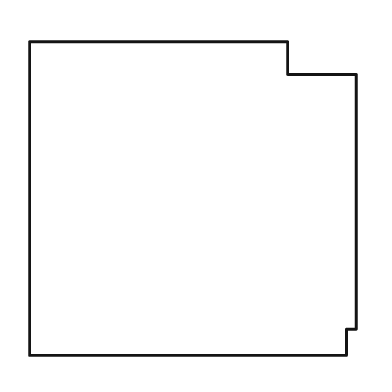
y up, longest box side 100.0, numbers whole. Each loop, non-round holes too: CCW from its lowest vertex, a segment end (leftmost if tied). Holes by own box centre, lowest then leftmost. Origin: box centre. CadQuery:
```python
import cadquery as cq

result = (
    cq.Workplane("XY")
    .moveTo(-50.0, -48.0)
    .lineTo(47.0, -48.0)
    .lineTo(47.0, -40.0)
    .lineTo(50.0, -40.0)
    .lineTo(50.0, 38.0)
    .lineTo(29.0, 38.0)
    .lineTo(29.0, 48.0)
    .lineTo(-50.0, 48.0)
    .close()
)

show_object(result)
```